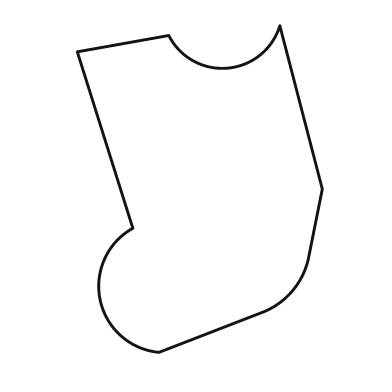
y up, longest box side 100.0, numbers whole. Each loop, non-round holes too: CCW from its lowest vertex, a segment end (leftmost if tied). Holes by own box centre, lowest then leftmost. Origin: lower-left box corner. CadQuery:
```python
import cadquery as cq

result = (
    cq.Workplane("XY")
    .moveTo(25.0, 0.0)
    .lineTo(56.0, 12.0)
    .threePointArc((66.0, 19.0), (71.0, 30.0))
    .lineTo(75.0, 50.0)
    .lineTo(62.0, 100.0)
    .threePointArc((46.0, 87.0), (28.0, 97.0))
    .lineTo(0.0, 92.0)
    .lineTo(17.0, 38.0)
    .threePointArc((7.0, 16.0), (25.0, 0.0))
    .close()
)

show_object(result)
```